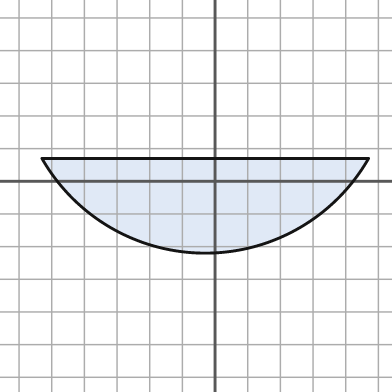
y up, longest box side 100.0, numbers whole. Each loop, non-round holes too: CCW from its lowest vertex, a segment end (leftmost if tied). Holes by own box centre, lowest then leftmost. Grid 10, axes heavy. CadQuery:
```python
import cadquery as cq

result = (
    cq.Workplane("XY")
    .moveTo(-53.0, 7.0)
    .threePointArc((-3.0, -22.0), (47.0, 7.0))
    .close()
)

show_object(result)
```